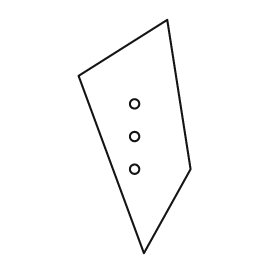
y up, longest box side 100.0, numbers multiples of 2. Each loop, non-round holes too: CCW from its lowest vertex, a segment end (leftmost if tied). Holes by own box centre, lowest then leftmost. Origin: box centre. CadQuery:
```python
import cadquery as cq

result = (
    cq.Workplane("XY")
    .moveTo(4.0, -50.0)
    .lineTo(24.0, -14.0)
    .lineTo(14.0, 50.0)
    .lineTo(-24.0, 26.0)
    .close()
    .moveTo(0.0, -14.0)
    .circle(2.0)
    .moveTo(0.0, 0.0)
    .circle(2.0)
    .moveTo(0.0, 14.0)
    .circle(2.0)
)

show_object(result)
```